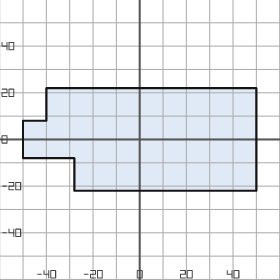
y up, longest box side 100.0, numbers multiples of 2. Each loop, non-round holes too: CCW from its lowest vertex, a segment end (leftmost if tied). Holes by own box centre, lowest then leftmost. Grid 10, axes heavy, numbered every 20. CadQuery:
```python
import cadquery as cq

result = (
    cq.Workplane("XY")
    .moveTo(-28.0, -22.0)
    .lineTo(50.0, -22.0)
    .lineTo(50.0, 22.0)
    .lineTo(-40.0, 22.0)
    .lineTo(-40.0, 8.0)
    .lineTo(-50.0, 8.0)
    .lineTo(-50.0, -8.0)
    .lineTo(-28.0, -8.0)
    .close()
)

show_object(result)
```